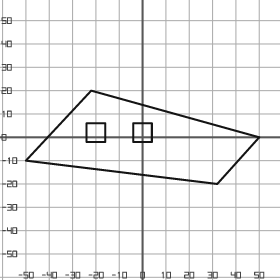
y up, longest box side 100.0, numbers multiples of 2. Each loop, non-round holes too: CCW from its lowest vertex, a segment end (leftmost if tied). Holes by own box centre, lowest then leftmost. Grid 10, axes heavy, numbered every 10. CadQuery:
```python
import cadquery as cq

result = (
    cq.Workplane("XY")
    .moveTo(32.0, -20.0)
    .lineTo(50.0, 0.0)
    .lineTo(-22.0, 20.0)
    .lineTo(-50.0, -10.0)
    .close()
    .moveTo(-24.0, -2.0)
    .lineTo(-16.0, -2.0)
    .lineTo(-16.0, 6.0)
    .lineTo(-24.0, 6.0)
    .close()
    .moveTo(-4.0, -2.0)
    .lineTo(4.0, -2.0)
    .lineTo(4.0, 6.0)
    .lineTo(-4.0, 6.0)
    .close()
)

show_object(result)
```